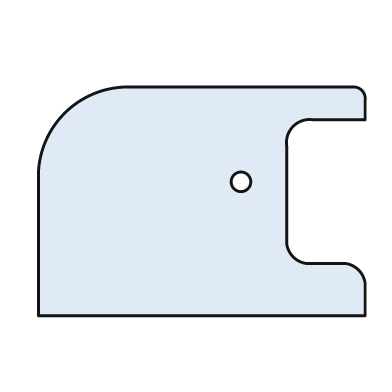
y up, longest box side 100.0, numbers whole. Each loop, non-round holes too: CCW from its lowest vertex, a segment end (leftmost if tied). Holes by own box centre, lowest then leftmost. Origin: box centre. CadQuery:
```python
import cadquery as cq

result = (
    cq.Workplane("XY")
    .moveTo(-50.0, -35.0)
    .lineTo(50.0, -35.0)
    .lineTo(50.0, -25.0)
    .threePointArc((48.0, -21.0), (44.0, -19.0))
    .lineTo(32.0, -19.0)
    .threePointArc((28.0, -17.0), (26.0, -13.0))
    .lineTo(26.0, 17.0)
    .threePointArc((28.0, 23.0), (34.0, 25.0))
    .lineTo(50.0, 25.0)
    .lineTo(50.0, 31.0)
    .threePointArc((49.0, 34.0), (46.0, 35.0))
    .lineTo(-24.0, 35.0)
    .threePointArc((-42.0, 27.0), (-50.0, 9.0))
    .close()
    .moveTo(12.0, 6.0)
    .circle(3.0)
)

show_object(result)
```